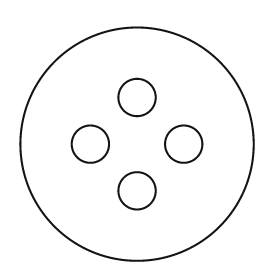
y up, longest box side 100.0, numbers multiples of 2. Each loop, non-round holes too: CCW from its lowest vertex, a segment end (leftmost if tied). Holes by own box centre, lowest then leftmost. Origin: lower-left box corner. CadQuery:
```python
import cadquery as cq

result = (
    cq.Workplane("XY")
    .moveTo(50.0, 50.0)
    .circle(50.0)
    .moveTo(50.0, 30.0)
    .circle(8.0)
    .moveTo(30.0, 50.0)
    .circle(8.0)
    .moveTo(70.0, 50.0)
    .circle(8.0)
    .moveTo(50.0, 70.0)
    .circle(8.0)
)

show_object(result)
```